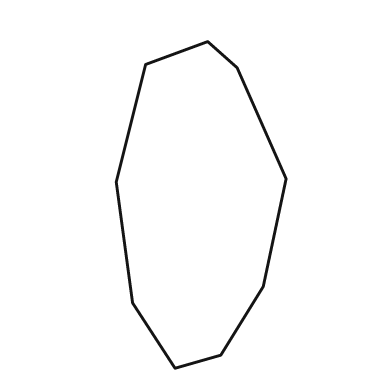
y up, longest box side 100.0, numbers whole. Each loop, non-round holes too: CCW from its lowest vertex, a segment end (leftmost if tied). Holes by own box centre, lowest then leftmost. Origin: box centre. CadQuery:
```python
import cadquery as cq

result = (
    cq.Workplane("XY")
    .moveTo(-8.0, -50.0)
    .lineTo(6.0, -46.0)
    .lineTo(19.0, -25.0)
    .lineTo(26.0, 8.0)
    .lineTo(11.0, 42.0)
    .lineTo(2.0, 50.0)
    .lineTo(-17.0, 43.0)
    .lineTo(-26.0, 7.0)
    .lineTo(-21.0, -30.0)
    .close()
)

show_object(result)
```